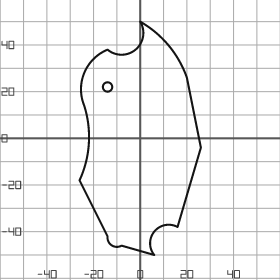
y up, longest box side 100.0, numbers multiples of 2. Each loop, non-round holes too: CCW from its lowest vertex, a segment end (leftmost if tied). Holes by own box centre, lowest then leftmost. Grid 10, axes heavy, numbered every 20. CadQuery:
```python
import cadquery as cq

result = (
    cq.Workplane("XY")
    .moveTo(6.0, -50.0)
    .threePointArc((6.0, -40.0), (16.0, -38.0))
    .lineTo(26.0, -4.0)
    .lineTo(20.0, 26.0)
    .threePointArc((12.0, 40.0), (0.0, 50.0))
    .threePointArc((-2.0, 38.0), (-14.0, 38.0))
    .threePointArc((-24.0, 28.0), (-24.0, 14.0))
    .threePointArc((-22.0, -2.0), (-26.0, -18.0))
    .lineTo(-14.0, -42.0)
    .threePointArc((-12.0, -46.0), (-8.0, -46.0))
    .close()
    .moveTo(-14.0, 22.0)
    .circle(2.0)
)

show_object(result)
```